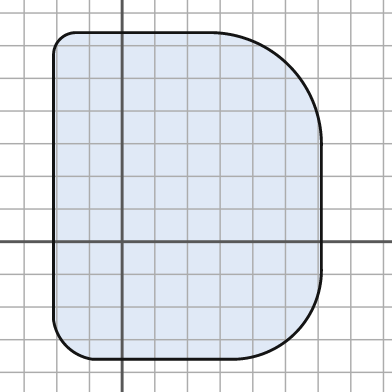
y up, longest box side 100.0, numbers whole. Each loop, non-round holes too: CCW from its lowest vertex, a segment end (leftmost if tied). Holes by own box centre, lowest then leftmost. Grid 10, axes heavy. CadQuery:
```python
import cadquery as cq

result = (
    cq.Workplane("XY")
    .moveTo(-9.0, -36.0)
    .lineTo(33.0, -36.0)
    .threePointArc((53.0, -28.0), (61.0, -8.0))
    .lineTo(61.0, 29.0)
    .threePointArc((51.0, 54.0), (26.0, 64.0))
    .lineTo(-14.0, 64.0)
    .threePointArc((-19.0, 62.0), (-21.0, 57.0))
    .lineTo(-21.0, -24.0)
    .threePointArc((-17.0, -32.0), (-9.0, -36.0))
    .close()
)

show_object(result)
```